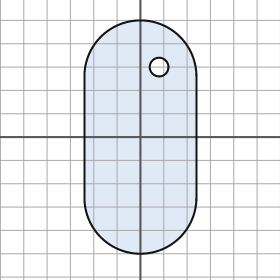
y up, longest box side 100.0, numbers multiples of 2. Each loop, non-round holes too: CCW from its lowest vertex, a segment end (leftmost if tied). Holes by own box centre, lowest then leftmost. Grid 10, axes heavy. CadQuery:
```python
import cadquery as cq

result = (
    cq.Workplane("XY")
    .moveTo(-24.0, -26.0)
    .threePointArc((0.0, -50.0), (24.0, -26.0))
    .lineTo(24.0, 26.0)
    .threePointArc((0.0, 50.0), (-24.0, 26.0))
    .close()
    .moveTo(8.0, 30.0)
    .circle(4.0)
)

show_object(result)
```